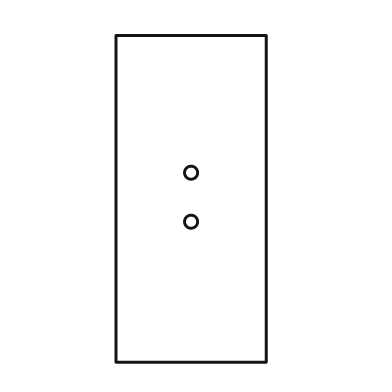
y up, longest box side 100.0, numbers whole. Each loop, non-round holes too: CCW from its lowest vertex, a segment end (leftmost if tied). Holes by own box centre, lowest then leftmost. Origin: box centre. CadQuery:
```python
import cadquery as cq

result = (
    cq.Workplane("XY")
    .moveTo(-23.0, -50.0)
    .lineTo(23.0, -50.0)
    .lineTo(23.0, 50.0)
    .lineTo(-23.0, 50.0)
    .close()
    .moveTo(0.0, -7.0)
    .circle(2.0)
    .moveTo(0.0, 8.0)
    .circle(2.0)
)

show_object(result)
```